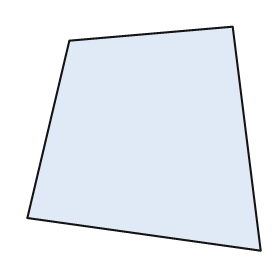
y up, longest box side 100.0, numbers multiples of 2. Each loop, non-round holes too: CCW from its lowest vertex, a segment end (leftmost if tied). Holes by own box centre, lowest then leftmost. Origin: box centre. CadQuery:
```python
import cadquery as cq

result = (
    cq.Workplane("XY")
    .moveTo(50.0, -48.0)
    .lineTo(38.0, 48.0)
    .lineTo(-32.0, 42.0)
    .lineTo(-50.0, -34.0)
    .close()
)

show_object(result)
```